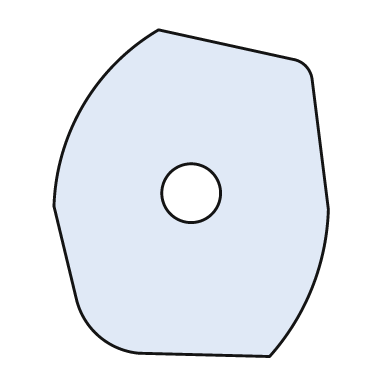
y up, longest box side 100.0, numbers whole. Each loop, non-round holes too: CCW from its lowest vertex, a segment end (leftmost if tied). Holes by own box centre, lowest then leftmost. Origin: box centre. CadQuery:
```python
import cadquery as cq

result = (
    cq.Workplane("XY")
    .moveTo(24.0, -50.0)
    .threePointArc((37.0, -29.0), (42.0, -5.0))
    .lineTo(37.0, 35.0)
    .threePointArc((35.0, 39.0), (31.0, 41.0))
    .lineTo(-10.0, 50.0)
    .threePointArc((-33.0, 27.0), (-42.0, -4.0))
    .lineTo(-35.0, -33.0)
    .threePointArc((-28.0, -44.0), (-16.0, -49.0))
    .close()
    .moveTo(0.0, 0.0)
    .circle(9.0)
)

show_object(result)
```